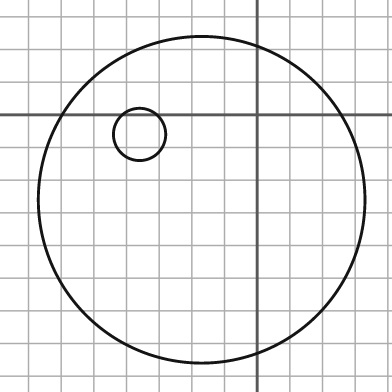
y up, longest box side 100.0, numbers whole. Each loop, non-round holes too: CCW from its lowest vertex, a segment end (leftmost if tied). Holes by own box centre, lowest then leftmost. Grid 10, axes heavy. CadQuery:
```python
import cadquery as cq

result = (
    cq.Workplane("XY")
    .moveTo(-17.0, -26.0)
    .circle(50.0)
    .moveTo(-36.0, -6.0)
    .circle(8.0)
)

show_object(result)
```